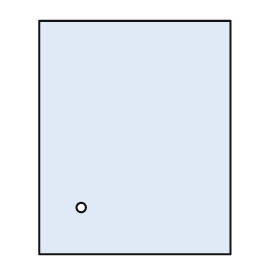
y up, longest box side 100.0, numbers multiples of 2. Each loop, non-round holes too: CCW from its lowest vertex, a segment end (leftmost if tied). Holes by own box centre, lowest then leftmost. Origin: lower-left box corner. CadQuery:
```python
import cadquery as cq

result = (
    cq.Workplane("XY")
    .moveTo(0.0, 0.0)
    .lineTo(82.0, 0.0)
    .lineTo(82.0, 100.0)
    .lineTo(0.0, 100.0)
    .close()
    .moveTo(18.0, 20.0)
    .circle(2.0)
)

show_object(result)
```